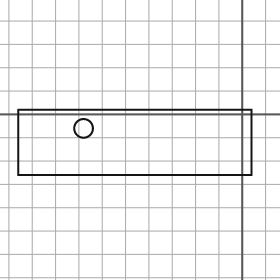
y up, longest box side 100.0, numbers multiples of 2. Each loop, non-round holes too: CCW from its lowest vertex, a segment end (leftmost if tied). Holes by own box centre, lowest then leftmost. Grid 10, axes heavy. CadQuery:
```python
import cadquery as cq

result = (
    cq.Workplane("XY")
    .moveTo(-96.0, -26.0)
    .lineTo(4.0, -26.0)
    .lineTo(4.0, 2.0)
    .lineTo(-96.0, 2.0)
    .close()
    .moveTo(-68.0, -6.0)
    .circle(4.0)
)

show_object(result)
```